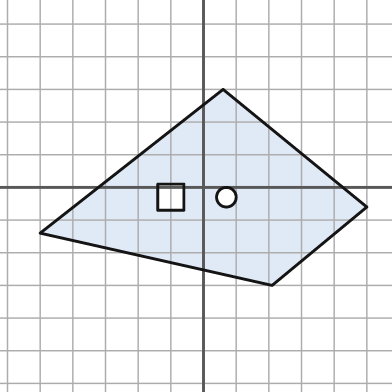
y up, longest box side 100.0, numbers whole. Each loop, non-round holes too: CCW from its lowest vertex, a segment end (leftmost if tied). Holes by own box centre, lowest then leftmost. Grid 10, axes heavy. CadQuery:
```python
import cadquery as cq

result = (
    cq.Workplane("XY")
    .moveTo(21.0, -30.0)
    .lineTo(50.0, -6.0)
    .lineTo(6.0, 30.0)
    .lineTo(-50.0, -14.0)
    .close()
    .moveTo(-14.0, -7.0)
    .lineTo(-6.0, -7.0)
    .lineTo(-6.0, 1.0)
    .lineTo(-14.0, 1.0)
    .close()
    .moveTo(7.0, -3.0)
    .circle(3.0)
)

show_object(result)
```